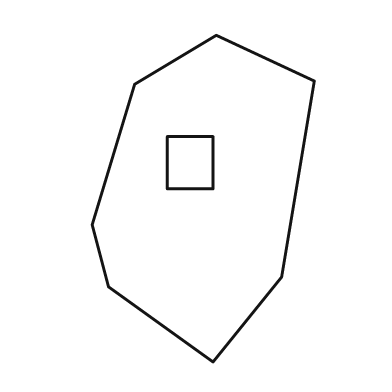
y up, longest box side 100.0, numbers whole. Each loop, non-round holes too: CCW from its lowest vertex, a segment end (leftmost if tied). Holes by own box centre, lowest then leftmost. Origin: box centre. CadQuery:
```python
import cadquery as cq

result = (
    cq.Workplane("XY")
    .moveTo(3.0, -50.0)
    .lineTo(24.0, -24.0)
    .lineTo(34.0, 36.0)
    .lineTo(4.0, 50.0)
    .lineTo(-21.0, 35.0)
    .lineTo(-34.0, -8.0)
    .lineTo(-29.0, -27.0)
    .close()
    .moveTo(-11.0, 3.0)
    .lineTo(3.0, 3.0)
    .lineTo(3.0, 19.0)
    .lineTo(-11.0, 19.0)
    .close()
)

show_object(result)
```